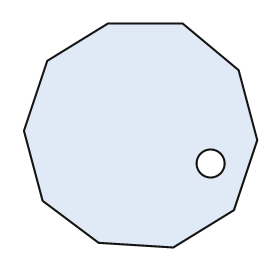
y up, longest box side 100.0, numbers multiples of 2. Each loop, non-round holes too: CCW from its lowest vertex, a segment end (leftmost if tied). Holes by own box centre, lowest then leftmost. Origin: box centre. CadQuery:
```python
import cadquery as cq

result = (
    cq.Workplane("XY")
    .moveTo(14.0, -48.0)
    .lineTo(40.0, -32.0)
    .lineTo(50.0, -2.0)
    .lineTo(42.0, 28.0)
    .lineTo(18.0, 48.0)
    .lineTo(-14.0, 48.0)
    .lineTo(-40.0, 32.0)
    .lineTo(-50.0, 2.0)
    .lineTo(-42.0, -28.0)
    .lineTo(-18.0, -46.0)
    .close()
    .moveTo(30.0, -12.0)
    .circle(6.0)
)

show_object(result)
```